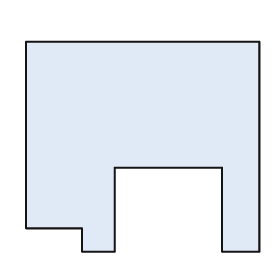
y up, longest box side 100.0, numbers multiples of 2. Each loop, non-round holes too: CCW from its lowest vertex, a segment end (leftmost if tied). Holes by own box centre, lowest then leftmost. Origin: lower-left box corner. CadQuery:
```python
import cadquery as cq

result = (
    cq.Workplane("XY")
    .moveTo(24.0, 0.0)
    .lineTo(38.0, 0.0)
    .lineTo(38.0, 36.0)
    .lineTo(84.0, 36.0)
    .lineTo(84.0, 0.0)
    .lineTo(100.0, 0.0)
    .lineTo(100.0, 90.0)
    .lineTo(0.0, 90.0)
    .lineTo(0.0, 10.0)
    .lineTo(24.0, 10.0)
    .close()
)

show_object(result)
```